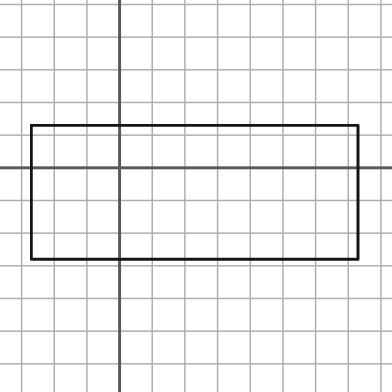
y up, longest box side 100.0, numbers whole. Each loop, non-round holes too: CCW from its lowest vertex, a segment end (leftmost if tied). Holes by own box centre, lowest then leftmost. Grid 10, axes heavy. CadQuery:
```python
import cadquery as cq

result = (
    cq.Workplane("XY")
    .moveTo(-27.0, -28.0)
    .lineTo(73.0, -28.0)
    .lineTo(73.0, 13.0)
    .lineTo(-27.0, 13.0)
    .close()
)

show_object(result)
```